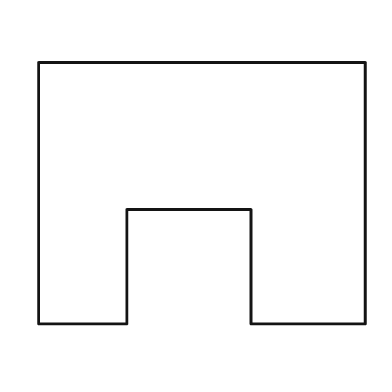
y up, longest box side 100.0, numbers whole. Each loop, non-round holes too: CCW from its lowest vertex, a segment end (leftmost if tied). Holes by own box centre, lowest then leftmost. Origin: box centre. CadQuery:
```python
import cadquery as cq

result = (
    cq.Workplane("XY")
    .moveTo(-50.0, -40.0)
    .lineTo(-23.0, -40.0)
    .lineTo(-23.0, -5.0)
    .lineTo(15.0, -5.0)
    .lineTo(15.0, -40.0)
    .lineTo(50.0, -40.0)
    .lineTo(50.0, 40.0)
    .lineTo(-50.0, 40.0)
    .close()
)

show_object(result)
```